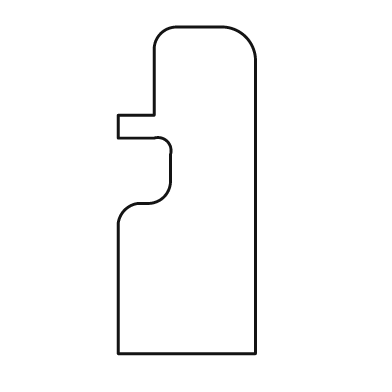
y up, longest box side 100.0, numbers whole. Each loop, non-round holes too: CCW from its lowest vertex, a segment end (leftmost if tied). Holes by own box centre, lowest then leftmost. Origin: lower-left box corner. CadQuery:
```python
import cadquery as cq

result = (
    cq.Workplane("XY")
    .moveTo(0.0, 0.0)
    .lineTo(42.0, 0.0)
    .lineTo(42.0, 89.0)
    .threePointArc((39.0, 97.0), (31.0, 100.0))
    .lineTo(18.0, 100.0)
    .threePointArc((13.0, 98.0), (11.0, 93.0))
    .lineTo(11.0, 73.0)
    .lineTo(0.0, 73.0)
    .lineTo(0.0, 66.0)
    .lineTo(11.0, 66.0)
    .threePointArc((15.0, 65.0), (16.0, 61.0))
    .lineTo(16.0, 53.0)
    .threePointArc((14.0, 48.0), (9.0, 46.0))
    .lineTo(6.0, 46.0)
    .threePointArc((2.0, 44.0), (0.0, 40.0))
    .close()
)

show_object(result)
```